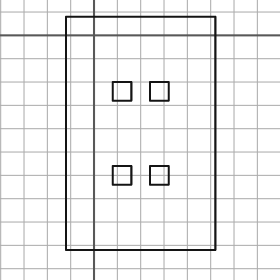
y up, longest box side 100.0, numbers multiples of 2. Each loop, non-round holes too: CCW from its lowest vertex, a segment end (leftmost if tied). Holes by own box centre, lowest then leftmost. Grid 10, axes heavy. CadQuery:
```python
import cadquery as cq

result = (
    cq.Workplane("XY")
    .moveTo(-12.0, -92.0)
    .lineTo(52.0, -92.0)
    .lineTo(52.0, 8.0)
    .lineTo(-12.0, 8.0)
    .close()
    .moveTo(8.0, -64.0)
    .lineTo(16.0, -64.0)
    .lineTo(16.0, -56.0)
    .lineTo(8.0, -56.0)
    .close()
    .moveTo(24.0, -64.0)
    .lineTo(32.0, -64.0)
    .lineTo(32.0, -56.0)
    .lineTo(24.0, -56.0)
    .close()
    .moveTo(8.0, -28.0)
    .lineTo(16.0, -28.0)
    .lineTo(16.0, -20.0)
    .lineTo(8.0, -20.0)
    .close()
    .moveTo(24.0, -28.0)
    .lineTo(32.0, -28.0)
    .lineTo(32.0, -20.0)
    .lineTo(24.0, -20.0)
    .close()
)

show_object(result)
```